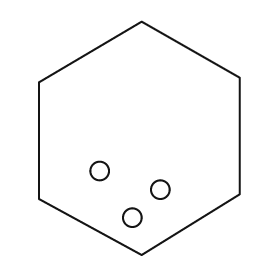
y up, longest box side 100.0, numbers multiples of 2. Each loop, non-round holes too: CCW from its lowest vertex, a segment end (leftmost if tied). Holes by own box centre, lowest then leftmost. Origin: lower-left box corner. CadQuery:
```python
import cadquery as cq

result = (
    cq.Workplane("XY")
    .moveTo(44.0, 0.0)
    .lineTo(86.0, 26.0)
    .lineTo(86.0, 76.0)
    .lineTo(44.0, 100.0)
    .lineTo(0.0, 74.0)
    .lineTo(0.0, 24.0)
    .close()
    .moveTo(40.0, 16.0)
    .circle(4.0)
    .moveTo(52.0, 28.0)
    .circle(4.0)
    .moveTo(26.0, 36.0)
    .circle(4.0)
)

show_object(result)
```